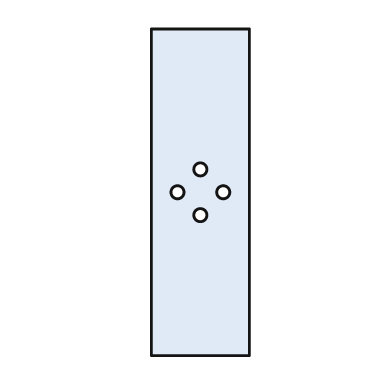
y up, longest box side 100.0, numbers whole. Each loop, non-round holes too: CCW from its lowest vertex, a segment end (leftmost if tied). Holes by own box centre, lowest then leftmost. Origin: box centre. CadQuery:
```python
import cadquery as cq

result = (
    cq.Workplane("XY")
    .moveTo(-15.0, -50.0)
    .lineTo(15.0, -50.0)
    .lineTo(15.0, 50.0)
    .lineTo(-15.0, 50.0)
    .close()
    .moveTo(0.0, -7.0)
    .circle(2.0)
    .moveTo(-7.0, 0.0)
    .circle(2.0)
    .moveTo(7.0, 0.0)
    .circle(2.0)
    .moveTo(0.0, 7.0)
    .circle(2.0)
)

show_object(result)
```